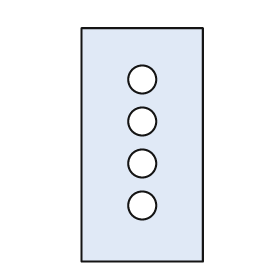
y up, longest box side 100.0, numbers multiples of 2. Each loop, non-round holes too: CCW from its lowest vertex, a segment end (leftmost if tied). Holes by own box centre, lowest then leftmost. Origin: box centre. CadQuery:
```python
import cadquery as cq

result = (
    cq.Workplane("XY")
    .moveTo(-26.0, -50.0)
    .lineTo(26.0, -50.0)
    .lineTo(26.0, 50.0)
    .lineTo(-26.0, 50.0)
    .close()
    .moveTo(0.0, -26.0)
    .circle(6.0)
    .moveTo(0.0, -8.0)
    .circle(6.0)
    .moveTo(0.0, 10.0)
    .circle(6.0)
    .moveTo(0.0, 28.0)
    .circle(6.0)
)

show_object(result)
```